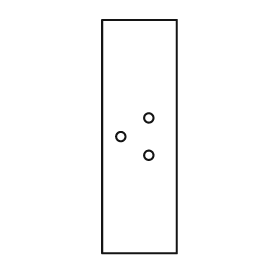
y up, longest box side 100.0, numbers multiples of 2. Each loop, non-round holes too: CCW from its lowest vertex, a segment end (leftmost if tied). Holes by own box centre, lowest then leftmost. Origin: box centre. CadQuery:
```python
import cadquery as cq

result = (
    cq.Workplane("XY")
    .moveTo(-16.0, -50.0)
    .lineTo(16.0, -50.0)
    .lineTo(16.0, 50.0)
    .lineTo(-16.0, 50.0)
    .close()
    .moveTo(4.0, -8.0)
    .circle(2.0)
    .moveTo(-8.0, 0.0)
    .circle(2.0)
    .moveTo(4.0, 8.0)
    .circle(2.0)
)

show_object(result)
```